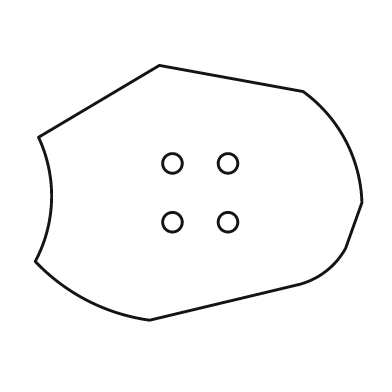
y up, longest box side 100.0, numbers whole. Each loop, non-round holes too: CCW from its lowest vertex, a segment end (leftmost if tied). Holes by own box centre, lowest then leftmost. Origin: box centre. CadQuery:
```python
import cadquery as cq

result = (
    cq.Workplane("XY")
    .moveTo(-15.0, -39.0)
    .lineTo(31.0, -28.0)
    .threePointArc((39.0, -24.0), (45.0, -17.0))
    .lineTo(50.0, -3.0)
    .threePointArc((45.0, 16.0), (32.0, 31.0))
    .lineTo(-12.0, 39.0)
    .lineTo(-49.0, 17.0)
    .threePointArc((-45.0, -2.0), (-50.0, -21.0))
    .threePointArc((-34.0, -33.0), (-15.0, -39.0))
    .close()
    .moveTo(-8.0, -9.0)
    .circle(3.0)
    .moveTo(9.0, -9.0)
    .circle(3.0)
    .moveTo(-8.0, 9.0)
    .circle(3.0)
    .moveTo(9.0, 9.0)
    .circle(3.0)
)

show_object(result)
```